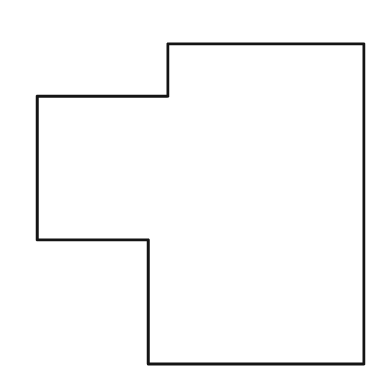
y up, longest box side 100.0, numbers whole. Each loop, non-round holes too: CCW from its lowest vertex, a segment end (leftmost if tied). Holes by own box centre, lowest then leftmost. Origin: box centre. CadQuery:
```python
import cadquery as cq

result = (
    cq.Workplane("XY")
    .moveTo(-16.0, -49.0)
    .lineTo(50.0, -49.0)
    .lineTo(50.0, 49.0)
    .lineTo(-10.0, 49.0)
    .lineTo(-10.0, 33.0)
    .lineTo(-50.0, 33.0)
    .lineTo(-50.0, -11.0)
    .lineTo(-16.0, -11.0)
    .close()
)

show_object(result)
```